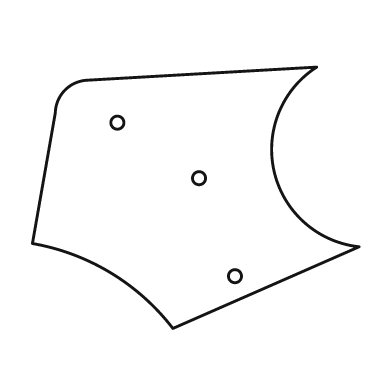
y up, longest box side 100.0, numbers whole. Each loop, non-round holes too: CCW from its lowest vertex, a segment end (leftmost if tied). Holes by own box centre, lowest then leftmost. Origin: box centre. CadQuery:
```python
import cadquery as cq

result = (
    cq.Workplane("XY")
    .moveTo(-7.0, -40.0)
    .lineTo(50.0, -15.0)
    .threePointArc((24.0, 8.0), (37.0, 40.0))
    .lineTo(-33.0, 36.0)
    .threePointArc((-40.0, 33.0), (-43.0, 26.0))
    .lineTo(-50.0, -14.0)
    .threePointArc((-26.0, -23.0), (-7.0, -40.0))
    .close()
    .moveTo(12.0, -24.0)
    .circle(2.0)
    .moveTo(1.0, 6.0)
    .circle(2.0)
    .moveTo(-24.0, 23.0)
    .circle(2.0)
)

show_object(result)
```